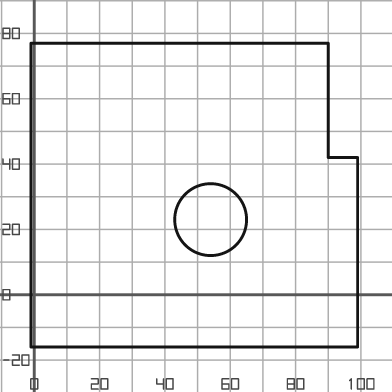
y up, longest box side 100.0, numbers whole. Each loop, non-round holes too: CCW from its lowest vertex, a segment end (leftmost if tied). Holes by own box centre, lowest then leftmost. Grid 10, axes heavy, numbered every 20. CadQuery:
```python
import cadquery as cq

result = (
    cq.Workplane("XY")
    .moveTo(-1.0, -16.0)
    .lineTo(99.0, -16.0)
    .lineTo(99.0, 42.0)
    .lineTo(90.0, 42.0)
    .lineTo(90.0, 77.0)
    .lineTo(-1.0, 77.0)
    .close()
    .moveTo(54.0, 23.0)
    .circle(11.0)
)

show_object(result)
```